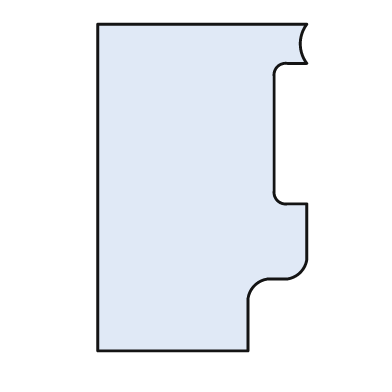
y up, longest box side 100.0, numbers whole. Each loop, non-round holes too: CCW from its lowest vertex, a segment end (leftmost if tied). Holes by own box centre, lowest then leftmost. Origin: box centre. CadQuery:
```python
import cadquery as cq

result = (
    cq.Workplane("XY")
    .moveTo(-32.0, -50.0)
    .lineTo(14.0, -50.0)
    .lineTo(14.0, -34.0)
    .threePointArc((16.0, -30.0), (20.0, -28.0))
    .lineTo(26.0, -28.0)
    .threePointArc((30.0, -26.0), (32.0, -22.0))
    .lineTo(32.0, -5.0)
    .lineTo(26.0, -5.0)
    .threePointArc((23.0, -4.0), (22.0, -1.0))
    .lineTo(22.0, 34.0)
    .threePointArc((23.0, 37.0), (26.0, 38.0))
    .lineTo(32.0, 38.0)
    .threePointArc((30.0, 44.0), (32.0, 50.0))
    .lineTo(-32.0, 50.0)
    .close()
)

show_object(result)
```